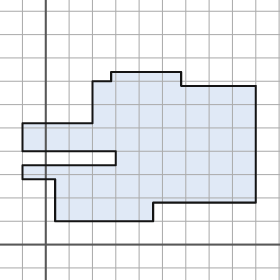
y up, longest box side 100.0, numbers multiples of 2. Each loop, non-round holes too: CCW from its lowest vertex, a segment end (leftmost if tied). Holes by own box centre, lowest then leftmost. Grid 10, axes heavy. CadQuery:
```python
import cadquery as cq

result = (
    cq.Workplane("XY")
    .moveTo(4.0, 10.0)
    .lineTo(46.0, 10.0)
    .lineTo(46.0, 18.0)
    .lineTo(90.0, 18.0)
    .lineTo(90.0, 68.0)
    .lineTo(58.0, 68.0)
    .lineTo(58.0, 74.0)
    .lineTo(28.0, 74.0)
    .lineTo(28.0, 70.0)
    .lineTo(20.0, 70.0)
    .lineTo(20.0, 52.0)
    .lineTo(-10.0, 52.0)
    .lineTo(-10.0, 40.0)
    .lineTo(30.0, 40.0)
    .lineTo(30.0, 34.0)
    .lineTo(-10.0, 34.0)
    .lineTo(-10.0, 28.0)
    .lineTo(4.0, 28.0)
    .close()
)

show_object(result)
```